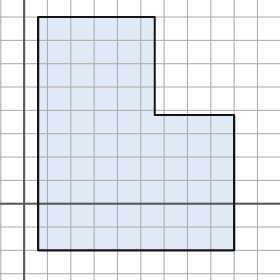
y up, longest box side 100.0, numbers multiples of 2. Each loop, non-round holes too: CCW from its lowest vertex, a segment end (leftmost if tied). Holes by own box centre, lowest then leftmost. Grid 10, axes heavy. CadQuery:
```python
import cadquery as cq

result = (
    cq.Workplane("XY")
    .moveTo(6.0, -20.0)
    .lineTo(90.0, -20.0)
    .lineTo(90.0, 38.0)
    .lineTo(56.0, 38.0)
    .lineTo(56.0, 80.0)
    .lineTo(6.0, 80.0)
    .close()
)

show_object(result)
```